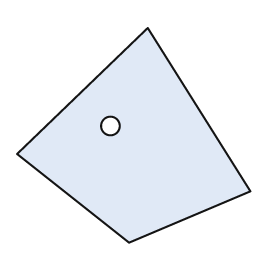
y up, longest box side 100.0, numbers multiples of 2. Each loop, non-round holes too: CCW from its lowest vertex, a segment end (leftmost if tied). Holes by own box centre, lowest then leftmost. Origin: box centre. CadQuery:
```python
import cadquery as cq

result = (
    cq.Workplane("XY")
    .moveTo(-2.0, -46.0)
    .lineTo(50.0, -24.0)
    .lineTo(6.0, 46.0)
    .lineTo(-50.0, -8.0)
    .close()
    .moveTo(-10.0, 4.0)
    .circle(4.0)
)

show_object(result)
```